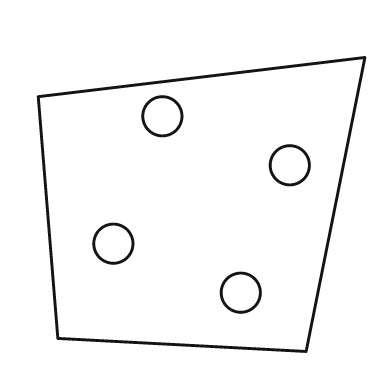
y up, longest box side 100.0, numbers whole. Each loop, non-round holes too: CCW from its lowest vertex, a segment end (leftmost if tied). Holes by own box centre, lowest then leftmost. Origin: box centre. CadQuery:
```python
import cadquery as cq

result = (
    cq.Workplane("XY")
    .moveTo(32.0, -45.0)
    .lineTo(50.0, 45.0)
    .lineTo(-50.0, 33.0)
    .lineTo(-44.0, -41.0)
    .close()
    .moveTo(12.0, -27.0)
    .circle(6.0)
    .moveTo(-27.0, -12.0)
    .circle(6.0)
    .moveTo(27.0, 12.0)
    .circle(6.0)
    .moveTo(-12.0, 27.0)
    .circle(6.0)
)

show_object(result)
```